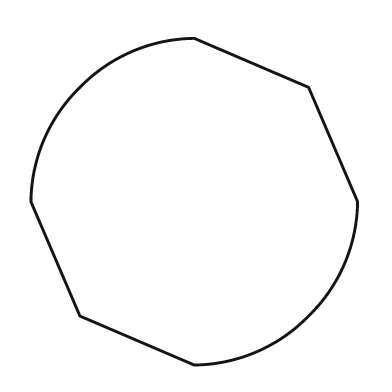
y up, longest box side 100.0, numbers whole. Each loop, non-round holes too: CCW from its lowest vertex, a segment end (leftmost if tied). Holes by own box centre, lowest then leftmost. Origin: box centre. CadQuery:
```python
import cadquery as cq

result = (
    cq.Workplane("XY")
    .moveTo(0.0, -50.0)
    .threePointArc((19.0, -46.0), (35.0, -35.0))
    .threePointArc((46.0, -19.0), (50.0, 0.0))
    .lineTo(35.0, 35.0)
    .lineTo(0.0, 50.0)
    .threePointArc((-19.0, 46.0), (-35.0, 35.0))
    .threePointArc((-46.0, 19.0), (-50.0, 0.0))
    .lineTo(-35.0, -35.0)
    .close()
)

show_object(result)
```